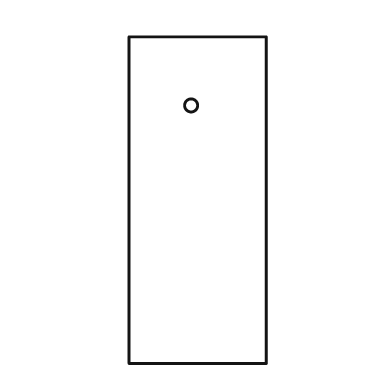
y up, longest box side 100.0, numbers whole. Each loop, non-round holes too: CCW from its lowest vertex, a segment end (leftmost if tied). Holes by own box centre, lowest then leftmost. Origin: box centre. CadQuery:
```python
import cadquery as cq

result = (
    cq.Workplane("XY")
    .moveTo(-21.0, -50.0)
    .lineTo(21.0, -50.0)
    .lineTo(21.0, 50.0)
    .lineTo(-21.0, 50.0)
    .close()
    .moveTo(-2.0, 29.0)
    .circle(2.0)
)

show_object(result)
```